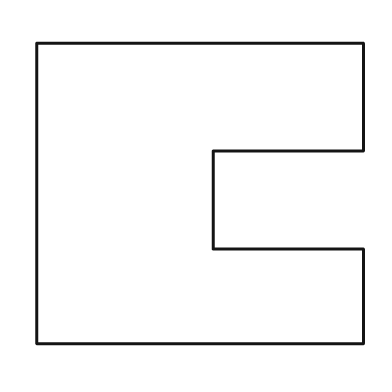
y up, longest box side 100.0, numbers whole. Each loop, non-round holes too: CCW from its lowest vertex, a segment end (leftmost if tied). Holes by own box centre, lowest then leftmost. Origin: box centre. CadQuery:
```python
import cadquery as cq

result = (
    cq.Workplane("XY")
    .moveTo(-50.0, -46.0)
    .lineTo(50.0, -46.0)
    .lineTo(50.0, -17.0)
    .lineTo(4.0, -17.0)
    .lineTo(4.0, 13.0)
    .lineTo(50.0, 13.0)
    .lineTo(50.0, 46.0)
    .lineTo(-50.0, 46.0)
    .close()
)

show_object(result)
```